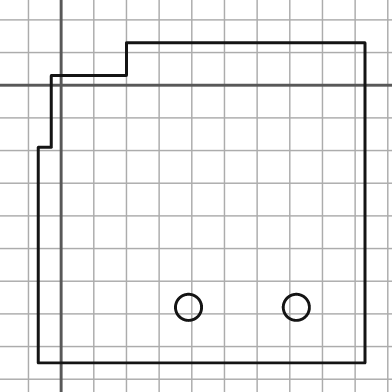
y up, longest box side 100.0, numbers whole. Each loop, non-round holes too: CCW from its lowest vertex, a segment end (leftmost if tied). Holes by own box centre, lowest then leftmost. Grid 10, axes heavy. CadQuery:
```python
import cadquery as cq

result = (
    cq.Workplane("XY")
    .moveTo(-7.0, -85.0)
    .lineTo(93.0, -85.0)
    .lineTo(93.0, 13.0)
    .lineTo(20.0, 13.0)
    .lineTo(20.0, 3.0)
    .lineTo(-3.0, 3.0)
    .lineTo(-3.0, -19.0)
    .lineTo(-7.0, -19.0)
    .close()
    .moveTo(39.0, -68.0)
    .circle(4.0)
    .moveTo(72.0, -68.0)
    .circle(4.0)
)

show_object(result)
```